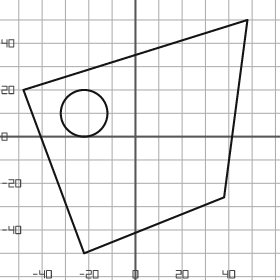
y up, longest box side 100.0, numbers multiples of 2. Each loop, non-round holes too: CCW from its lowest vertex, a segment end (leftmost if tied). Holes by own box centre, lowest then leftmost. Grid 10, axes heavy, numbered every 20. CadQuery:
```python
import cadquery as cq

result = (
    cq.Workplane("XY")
    .moveTo(-22.0, -50.0)
    .lineTo(38.0, -26.0)
    .lineTo(48.0, 50.0)
    .lineTo(-48.0, 20.0)
    .close()
    .moveTo(-22.0, 10.0)
    .circle(10.0)
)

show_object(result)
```